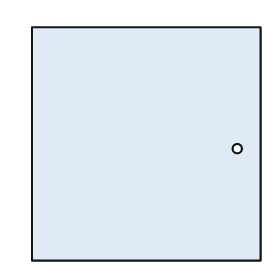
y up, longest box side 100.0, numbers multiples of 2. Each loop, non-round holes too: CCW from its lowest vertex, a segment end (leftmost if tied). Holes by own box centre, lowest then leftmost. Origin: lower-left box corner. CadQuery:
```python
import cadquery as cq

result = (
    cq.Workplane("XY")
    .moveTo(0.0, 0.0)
    .lineTo(98.0, 0.0)
    .lineTo(98.0, 100.0)
    .lineTo(0.0, 100.0)
    .close()
    .moveTo(88.0, 48.0)
    .circle(2.0)
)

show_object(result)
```